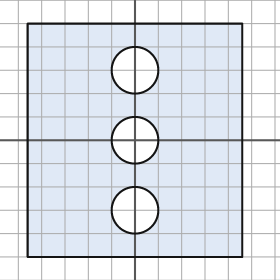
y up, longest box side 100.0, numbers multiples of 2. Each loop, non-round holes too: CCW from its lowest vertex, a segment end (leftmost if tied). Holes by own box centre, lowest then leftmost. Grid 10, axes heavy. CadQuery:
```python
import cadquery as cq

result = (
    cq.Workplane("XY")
    .moveTo(-46.0, -50.0)
    .lineTo(46.0, -50.0)
    .lineTo(46.0, 50.0)
    .lineTo(-46.0, 50.0)
    .close()
    .moveTo(0.0, -30.0)
    .circle(10.0)
    .moveTo(0.0, 0.0)
    .circle(10.0)
    .moveTo(0.0, 30.0)
    .circle(10.0)
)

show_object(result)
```